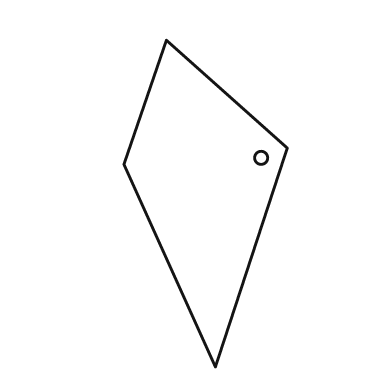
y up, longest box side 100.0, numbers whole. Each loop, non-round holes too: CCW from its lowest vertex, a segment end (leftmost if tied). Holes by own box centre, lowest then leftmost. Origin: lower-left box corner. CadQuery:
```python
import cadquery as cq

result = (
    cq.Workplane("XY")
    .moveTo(28.0, 0.0)
    .lineTo(50.0, 67.0)
    .lineTo(13.0, 100.0)
    .lineTo(0.0, 62.0)
    .close()
    .moveTo(42.0, 64.0)
    .circle(2.0)
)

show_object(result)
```